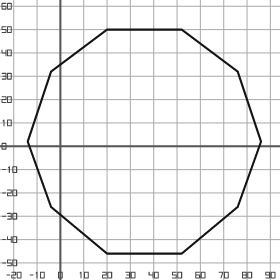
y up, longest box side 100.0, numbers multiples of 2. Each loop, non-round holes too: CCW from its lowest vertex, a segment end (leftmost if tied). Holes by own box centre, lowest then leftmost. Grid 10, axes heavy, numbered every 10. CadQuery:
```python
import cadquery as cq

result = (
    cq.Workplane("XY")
    .moveTo(20.0, -46.0)
    .lineTo(52.0, -46.0)
    .lineTo(76.0, -26.0)
    .lineTo(86.0, 2.0)
    .lineTo(76.0, 32.0)
    .lineTo(52.0, 50.0)
    .lineTo(20.0, 50.0)
    .lineTo(-4.0, 32.0)
    .lineTo(-14.0, 2.0)
    .lineTo(-4.0, -26.0)
    .close()
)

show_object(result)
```